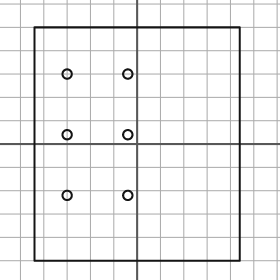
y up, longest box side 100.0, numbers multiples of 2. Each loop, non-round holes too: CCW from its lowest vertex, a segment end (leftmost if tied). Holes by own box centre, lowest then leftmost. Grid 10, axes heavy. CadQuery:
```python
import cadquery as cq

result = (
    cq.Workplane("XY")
    .moveTo(-44.0, -50.0)
    .lineTo(44.0, -50.0)
    .lineTo(44.0, 50.0)
    .lineTo(-44.0, 50.0)
    .close()
    .moveTo(-30.0, -22.0)
    .circle(2.0)
    .moveTo(-4.0, -22.0)
    .circle(2.0)
    .moveTo(-30.0, 4.0)
    .circle(2.0)
    .moveTo(-4.0, 4.0)
    .circle(2.0)
    .moveTo(-30.0, 30.0)
    .circle(2.0)
    .moveTo(-4.0, 30.0)
    .circle(2.0)
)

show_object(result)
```